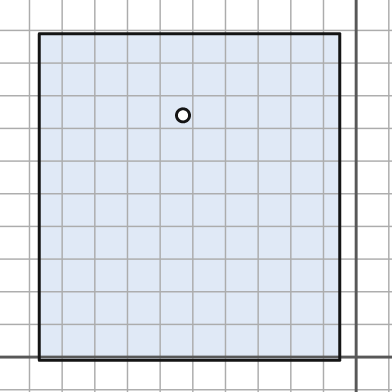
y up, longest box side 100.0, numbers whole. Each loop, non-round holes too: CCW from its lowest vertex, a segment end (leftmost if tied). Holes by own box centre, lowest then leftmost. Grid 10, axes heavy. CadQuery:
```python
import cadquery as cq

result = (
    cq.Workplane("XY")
    .moveTo(-97.0, -1.0)
    .lineTo(-5.0, -1.0)
    .lineTo(-5.0, 99.0)
    .lineTo(-97.0, 99.0)
    .close()
    .moveTo(-53.0, 74.0)
    .circle(2.0)
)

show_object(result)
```